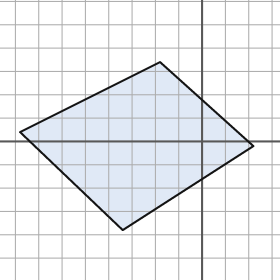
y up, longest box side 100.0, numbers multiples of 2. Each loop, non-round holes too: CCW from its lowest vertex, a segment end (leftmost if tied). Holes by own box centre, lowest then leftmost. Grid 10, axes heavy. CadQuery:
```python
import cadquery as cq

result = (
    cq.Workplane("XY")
    .moveTo(-34.0, -38.0)
    .lineTo(22.0, -2.0)
    .lineTo(-18.0, 34.0)
    .lineTo(-78.0, 4.0)
    .close()
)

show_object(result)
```